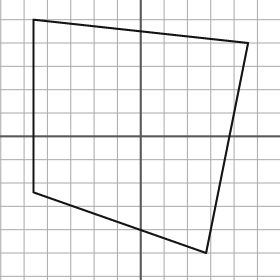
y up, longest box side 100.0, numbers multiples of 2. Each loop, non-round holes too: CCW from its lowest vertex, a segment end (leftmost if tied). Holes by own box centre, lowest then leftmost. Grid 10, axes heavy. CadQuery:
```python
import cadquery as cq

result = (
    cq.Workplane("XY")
    .moveTo(28.0, -50.0)
    .lineTo(46.0, 40.0)
    .lineTo(-46.0, 50.0)
    .lineTo(-46.0, -24.0)
    .close()
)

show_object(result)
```